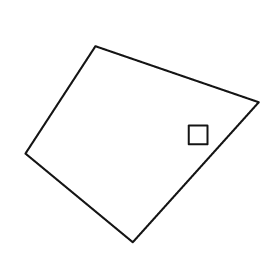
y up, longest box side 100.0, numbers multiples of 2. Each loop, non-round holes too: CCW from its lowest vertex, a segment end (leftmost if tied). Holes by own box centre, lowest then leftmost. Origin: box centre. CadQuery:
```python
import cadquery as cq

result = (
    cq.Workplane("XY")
    .moveTo(-4.0, -42.0)
    .lineTo(50.0, 18.0)
    .lineTo(-20.0, 42.0)
    .lineTo(-50.0, -4.0)
    .close()
    .moveTo(20.0, 0.0)
    .lineTo(28.0, 0.0)
    .lineTo(28.0, 8.0)
    .lineTo(20.0, 8.0)
    .close()
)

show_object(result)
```